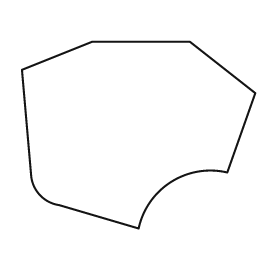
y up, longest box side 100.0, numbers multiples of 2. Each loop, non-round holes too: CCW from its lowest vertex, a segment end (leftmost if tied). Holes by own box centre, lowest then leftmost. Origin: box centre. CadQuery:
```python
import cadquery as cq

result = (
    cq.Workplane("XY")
    .moveTo(0.0, -40.0)
    .threePointArc((14.0, -20.0), (38.0, -16.0))
    .lineTo(50.0, 18.0)
    .lineTo(22.0, 40.0)
    .lineTo(-20.0, 40.0)
    .lineTo(-50.0, 28.0)
    .lineTo(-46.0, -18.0)
    .threePointArc((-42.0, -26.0), (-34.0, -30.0))
    .close()
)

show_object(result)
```